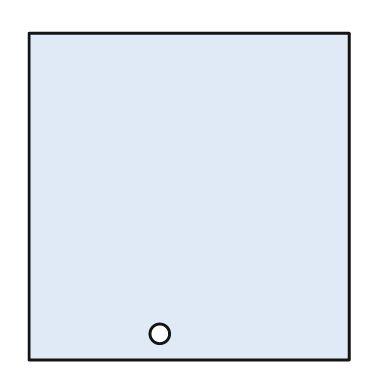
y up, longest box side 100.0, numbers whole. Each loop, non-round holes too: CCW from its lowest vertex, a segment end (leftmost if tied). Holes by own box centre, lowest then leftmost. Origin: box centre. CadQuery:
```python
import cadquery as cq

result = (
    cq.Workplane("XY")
    .moveTo(-49.0, -50.0)
    .lineTo(49.0, -50.0)
    .lineTo(49.0, 50.0)
    .lineTo(-49.0, 50.0)
    .close()
    .moveTo(-9.0, -42.0)
    .circle(3.0)
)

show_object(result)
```